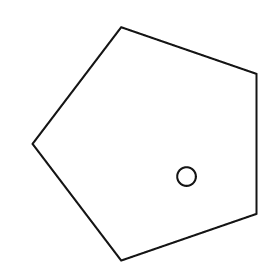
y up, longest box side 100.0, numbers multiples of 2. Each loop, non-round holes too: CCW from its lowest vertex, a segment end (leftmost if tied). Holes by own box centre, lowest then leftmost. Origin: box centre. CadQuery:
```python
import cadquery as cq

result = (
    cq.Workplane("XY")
    .moveTo(-10.0, -50.0)
    .lineTo(48.0, -30.0)
    .lineTo(48.0, 30.0)
    .lineTo(-10.0, 50.0)
    .lineTo(-48.0, 0.0)
    .close()
    .moveTo(18.0, -14.0)
    .circle(4.0)
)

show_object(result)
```